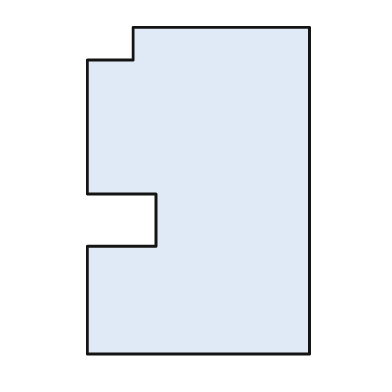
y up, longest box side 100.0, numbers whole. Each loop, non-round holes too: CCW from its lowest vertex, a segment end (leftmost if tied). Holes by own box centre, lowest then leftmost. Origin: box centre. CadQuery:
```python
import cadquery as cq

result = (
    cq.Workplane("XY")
    .moveTo(-34.0, -50.0)
    .lineTo(34.0, -50.0)
    .lineTo(34.0, 50.0)
    .lineTo(-20.0, 50.0)
    .lineTo(-20.0, 40.0)
    .lineTo(-34.0, 40.0)
    .lineTo(-34.0, -1.0)
    .lineTo(-13.0, -1.0)
    .lineTo(-13.0, -17.0)
    .lineTo(-34.0, -17.0)
    .close()
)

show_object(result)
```